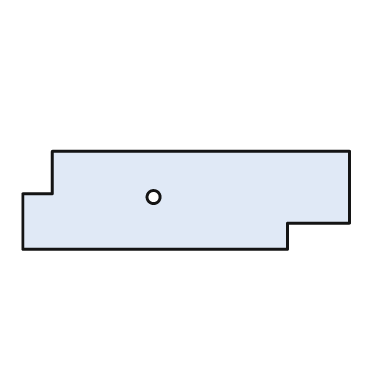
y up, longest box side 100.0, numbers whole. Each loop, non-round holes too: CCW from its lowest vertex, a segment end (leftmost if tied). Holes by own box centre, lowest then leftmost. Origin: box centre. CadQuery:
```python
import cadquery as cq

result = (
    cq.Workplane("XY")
    .moveTo(-50.0, -15.0)
    .lineTo(31.0, -15.0)
    .lineTo(31.0, -7.0)
    .lineTo(50.0, -7.0)
    .lineTo(50.0, 15.0)
    .lineTo(-41.0, 15.0)
    .lineTo(-41.0, 2.0)
    .lineTo(-50.0, 2.0)
    .close()
    .moveTo(-10.0, 1.0)
    .circle(2.0)
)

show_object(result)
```